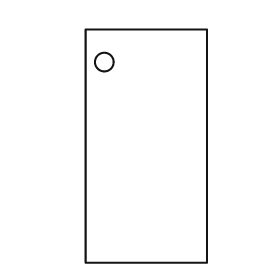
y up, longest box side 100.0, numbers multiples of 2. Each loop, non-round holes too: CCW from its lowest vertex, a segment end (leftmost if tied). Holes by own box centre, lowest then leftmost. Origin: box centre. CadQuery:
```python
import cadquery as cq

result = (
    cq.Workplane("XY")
    .moveTo(-26.0, -50.0)
    .lineTo(26.0, -50.0)
    .lineTo(26.0, 50.0)
    .lineTo(-26.0, 50.0)
    .close()
    .moveTo(-18.0, 36.0)
    .circle(4.0)
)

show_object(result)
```